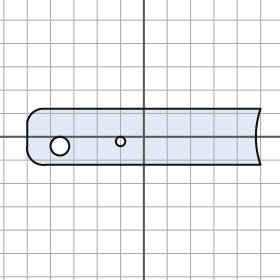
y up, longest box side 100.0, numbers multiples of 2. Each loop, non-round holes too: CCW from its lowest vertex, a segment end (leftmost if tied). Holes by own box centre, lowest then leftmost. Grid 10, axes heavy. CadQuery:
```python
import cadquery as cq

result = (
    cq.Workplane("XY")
    .moveTo(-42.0, -12.0)
    .lineTo(50.0, -12.0)
    .threePointArc((48.0, 0.0), (50.0, 12.0))
    .lineTo(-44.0, 12.0)
    .threePointArc((-48.0, 10.0), (-50.0, 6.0))
    .lineTo(-50.0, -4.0)
    .threePointArc((-48.0, -10.0), (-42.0, -12.0))
    .close()
    .moveTo(-36.0, -4.0)
    .circle(4.0)
    .moveTo(-10.0, -2.0)
    .circle(2.0)
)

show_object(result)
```